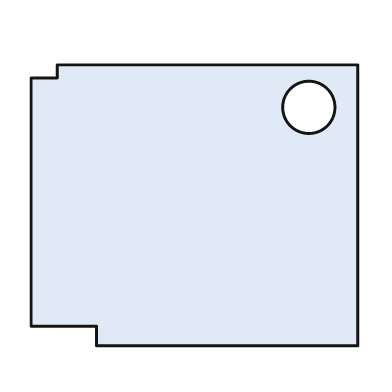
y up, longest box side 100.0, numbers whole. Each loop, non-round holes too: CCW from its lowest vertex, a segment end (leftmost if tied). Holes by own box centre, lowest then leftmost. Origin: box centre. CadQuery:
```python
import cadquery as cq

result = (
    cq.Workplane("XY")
    .moveTo(-30.0, -43.0)
    .lineTo(50.0, -43.0)
    .lineTo(50.0, 43.0)
    .lineTo(-42.0, 43.0)
    .lineTo(-42.0, 39.0)
    .lineTo(-50.0, 39.0)
    .lineTo(-50.0, -37.0)
    .lineTo(-30.0, -37.0)
    .close()
    .moveTo(35.0, 30.0)
    .circle(8.0)
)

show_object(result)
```